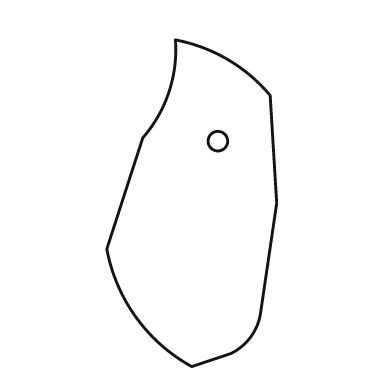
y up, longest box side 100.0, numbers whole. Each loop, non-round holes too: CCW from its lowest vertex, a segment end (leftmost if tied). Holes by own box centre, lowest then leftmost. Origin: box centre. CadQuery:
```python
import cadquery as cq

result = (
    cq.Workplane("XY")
    .moveTo(0.0, -50.0)
    .lineTo(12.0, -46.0)
    .threePointArc((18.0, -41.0), (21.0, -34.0))
    .lineTo(26.0, 0.0)
    .lineTo(24.0, 33.0)
    .threePointArc((11.0, 44.0), (-5.0, 50.0))
    .threePointArc((-7.0, 34.0), (-15.0, 20.0))
    .lineTo(-26.0, -14.0)
    .threePointArc((-17.0, -35.0), (0.0, -50.0))
    .close()
    .moveTo(8.0, 19.0)
    .circle(3.0)
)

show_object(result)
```